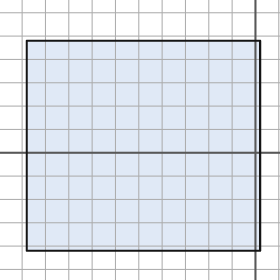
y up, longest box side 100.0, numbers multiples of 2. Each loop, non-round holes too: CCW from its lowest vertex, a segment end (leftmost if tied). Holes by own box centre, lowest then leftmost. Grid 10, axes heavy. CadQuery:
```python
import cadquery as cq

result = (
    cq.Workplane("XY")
    .moveTo(-98.0, -42.0)
    .lineTo(2.0, -42.0)
    .lineTo(2.0, 48.0)
    .lineTo(-98.0, 48.0)
    .close()
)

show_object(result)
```